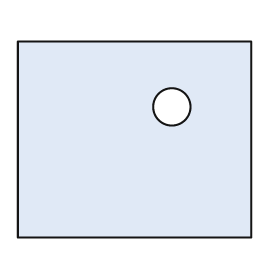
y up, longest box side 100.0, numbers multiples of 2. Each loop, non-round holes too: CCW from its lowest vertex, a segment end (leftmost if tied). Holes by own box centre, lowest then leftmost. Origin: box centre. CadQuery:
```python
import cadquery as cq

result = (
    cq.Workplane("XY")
    .moveTo(-50.0, -42.0)
    .lineTo(50.0, -42.0)
    .lineTo(50.0, 42.0)
    .lineTo(-50.0, 42.0)
    .close()
    .moveTo(16.0, 14.0)
    .circle(8.0)
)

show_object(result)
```